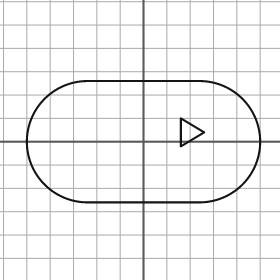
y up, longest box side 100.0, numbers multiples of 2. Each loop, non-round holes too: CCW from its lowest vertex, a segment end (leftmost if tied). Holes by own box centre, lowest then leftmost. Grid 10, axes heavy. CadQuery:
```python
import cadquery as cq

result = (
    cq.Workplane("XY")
    .moveTo(-24.0, -26.0)
    .lineTo(24.0, -26.0)
    .threePointArc((50.0, 0.0), (24.0, 26.0))
    .lineTo(-24.0, 26.0)
    .threePointArc((-50.0, 0.0), (-24.0, -26.0))
    .close()
    .moveTo(16.0, -2.0)
    .lineTo(26.0, 4.0)
    .lineTo(16.0, 10.0)
    .close()
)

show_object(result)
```